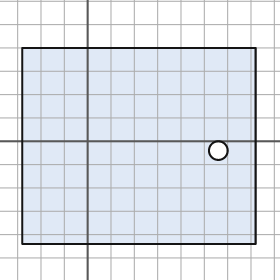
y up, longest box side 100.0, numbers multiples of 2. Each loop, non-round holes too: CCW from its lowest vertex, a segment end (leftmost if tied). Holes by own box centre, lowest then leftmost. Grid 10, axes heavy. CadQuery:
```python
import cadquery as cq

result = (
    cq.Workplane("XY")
    .moveTo(-28.0, -44.0)
    .lineTo(72.0, -44.0)
    .lineTo(72.0, 40.0)
    .lineTo(-28.0, 40.0)
    .close()
    .moveTo(56.0, -4.0)
    .circle(4.0)
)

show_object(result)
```